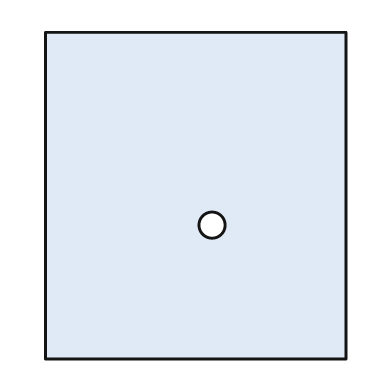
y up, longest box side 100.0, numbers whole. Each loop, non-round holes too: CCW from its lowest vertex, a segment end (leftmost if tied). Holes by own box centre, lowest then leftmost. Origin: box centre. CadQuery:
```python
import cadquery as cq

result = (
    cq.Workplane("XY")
    .moveTo(-46.0, -50.0)
    .lineTo(46.0, -50.0)
    .lineTo(46.0, 50.0)
    .lineTo(-46.0, 50.0)
    .close()
    .moveTo(5.0, -9.0)
    .circle(4.0)
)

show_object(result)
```